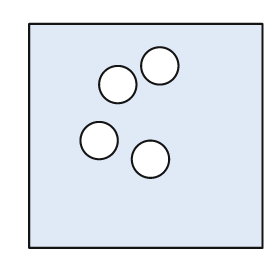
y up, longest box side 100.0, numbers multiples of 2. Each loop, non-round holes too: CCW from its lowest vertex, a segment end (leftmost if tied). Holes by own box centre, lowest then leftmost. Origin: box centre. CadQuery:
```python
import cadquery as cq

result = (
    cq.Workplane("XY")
    .moveTo(-50.0, -48.0)
    .lineTo(50.0, -48.0)
    .lineTo(50.0, 48.0)
    .lineTo(-50.0, 48.0)
    .close()
    .moveTo(2.0, -10.0)
    .circle(8.0)
    .moveTo(-20.0, -2.0)
    .circle(8.0)
    .moveTo(-12.0, 22.0)
    .circle(8.0)
    .moveTo(6.0, 30.0)
    .circle(8.0)
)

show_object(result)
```